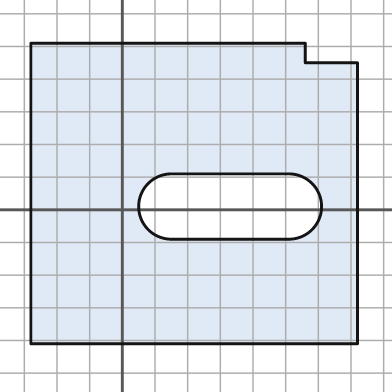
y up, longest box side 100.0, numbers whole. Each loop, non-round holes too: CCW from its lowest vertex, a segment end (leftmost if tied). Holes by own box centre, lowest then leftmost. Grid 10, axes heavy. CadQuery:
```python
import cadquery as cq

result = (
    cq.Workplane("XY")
    .moveTo(-28.0, -41.0)
    .lineTo(72.0, -41.0)
    .lineTo(72.0, 45.0)
    .lineTo(56.0, 45.0)
    .lineTo(56.0, 51.0)
    .lineTo(-28.0, 51.0)
    .close()
    .moveTo(15.0, -9.0)
    .lineTo(51.0, -9.0)
    .threePointArc((61.0, 1.0), (51.0, 11.0))
    .lineTo(15.0, 11.0)
    .threePointArc((5.0, 1.0), (15.0, -9.0))
    .close()
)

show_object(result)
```